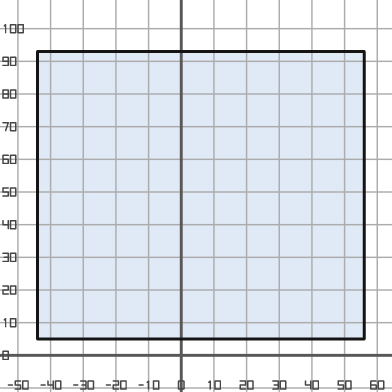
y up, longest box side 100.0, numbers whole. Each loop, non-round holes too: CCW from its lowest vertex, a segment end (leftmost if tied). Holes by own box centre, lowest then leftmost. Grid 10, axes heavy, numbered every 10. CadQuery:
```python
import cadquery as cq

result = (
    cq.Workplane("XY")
    .moveTo(-44.0, 5.0)
    .lineTo(56.0, 5.0)
    .lineTo(56.0, 93.0)
    .lineTo(-44.0, 93.0)
    .close()
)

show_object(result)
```